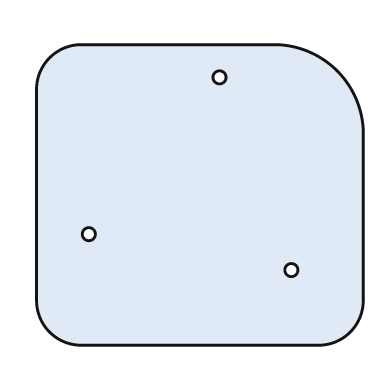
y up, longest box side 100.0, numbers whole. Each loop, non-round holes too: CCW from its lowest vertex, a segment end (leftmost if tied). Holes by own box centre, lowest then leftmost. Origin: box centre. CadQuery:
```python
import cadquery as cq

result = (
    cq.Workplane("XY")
    .moveTo(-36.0, -46.0)
    .lineTo(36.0, -46.0)
    .threePointArc((46.0, -42.0), (50.0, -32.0))
    .lineTo(50.0, 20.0)
    .threePointArc((42.0, 38.0), (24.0, 46.0))
    .lineTo(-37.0, 46.0)
    .threePointArc((-46.0, 42.0), (-50.0, 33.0))
    .lineTo(-50.0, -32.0)
    .threePointArc((-46.0, -42.0), (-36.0, -46.0))
    .close()
    .moveTo(28.0, -23.0)
    .circle(2.0)
    .moveTo(-34.0, -12.0)
    .circle(2.0)
    .moveTo(6.0, 36.0)
    .circle(2.0)
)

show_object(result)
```